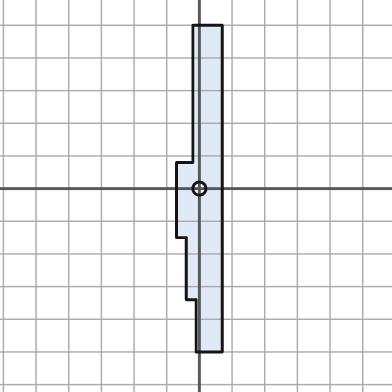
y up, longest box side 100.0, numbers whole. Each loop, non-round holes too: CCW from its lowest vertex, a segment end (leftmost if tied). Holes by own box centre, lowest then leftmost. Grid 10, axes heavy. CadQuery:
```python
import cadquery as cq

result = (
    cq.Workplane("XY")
    .moveTo(-1.0, -50.0)
    .lineTo(7.0, -50.0)
    .lineTo(7.0, 50.0)
    .lineTo(-2.0, 50.0)
    .lineTo(-2.0, 8.0)
    .lineTo(-7.0, 8.0)
    .lineTo(-7.0, -15.0)
    .lineTo(-4.0, -15.0)
    .lineTo(-4.0, -34.0)
    .lineTo(-1.0, -34.0)
    .close()
    .moveTo(0.0, 0.0)
    .circle(2.0)
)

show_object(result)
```